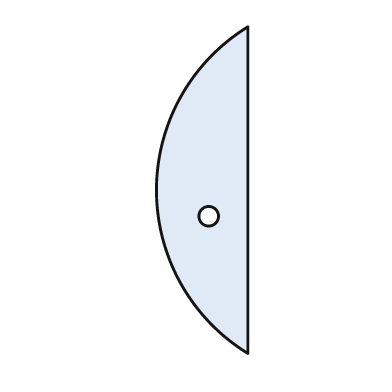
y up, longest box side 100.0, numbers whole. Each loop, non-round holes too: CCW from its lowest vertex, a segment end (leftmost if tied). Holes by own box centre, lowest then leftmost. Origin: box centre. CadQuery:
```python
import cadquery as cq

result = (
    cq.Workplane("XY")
    .moveTo(14.0, -50.0)
    .lineTo(14.0, 50.0)
    .threePointArc((-14.0, 0.0), (14.0, -50.0))
    .close()
    .moveTo(2.0, -8.0)
    .circle(3.0)
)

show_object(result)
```